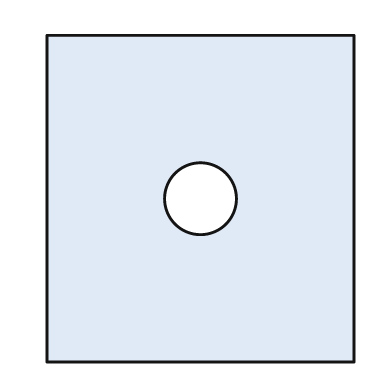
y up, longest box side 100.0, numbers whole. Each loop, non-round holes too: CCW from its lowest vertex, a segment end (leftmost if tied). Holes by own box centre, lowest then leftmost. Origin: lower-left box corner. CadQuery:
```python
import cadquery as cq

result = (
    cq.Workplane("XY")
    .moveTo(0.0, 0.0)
    .lineTo(94.0, 0.0)
    .lineTo(94.0, 100.0)
    .lineTo(0.0, 100.0)
    .close()
    .moveTo(47.0, 50.0)
    .circle(11.0)
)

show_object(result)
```